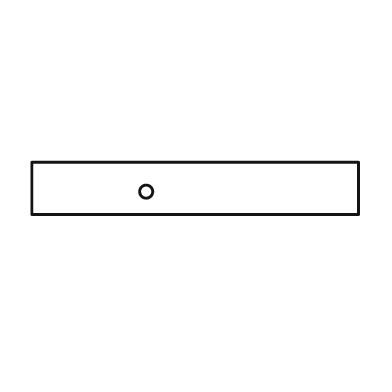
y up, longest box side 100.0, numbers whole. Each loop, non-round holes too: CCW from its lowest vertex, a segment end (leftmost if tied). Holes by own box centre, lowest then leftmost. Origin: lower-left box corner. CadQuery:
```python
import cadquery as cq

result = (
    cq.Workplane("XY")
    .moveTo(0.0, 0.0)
    .lineTo(100.0, 0.0)
    .lineTo(100.0, 16.0)
    .lineTo(0.0, 16.0)
    .close()
    .moveTo(35.0, 7.0)
    .circle(2.0)
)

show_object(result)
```